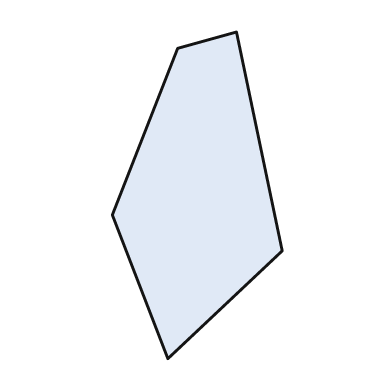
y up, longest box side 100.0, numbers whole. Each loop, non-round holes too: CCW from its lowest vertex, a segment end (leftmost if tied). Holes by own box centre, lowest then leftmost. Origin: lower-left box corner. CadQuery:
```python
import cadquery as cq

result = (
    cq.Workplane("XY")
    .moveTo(17.0, 0.0)
    .lineTo(52.0, 33.0)
    .lineTo(38.0, 100.0)
    .lineTo(20.0, 95.0)
    .lineTo(0.0, 44.0)
    .close()
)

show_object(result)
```